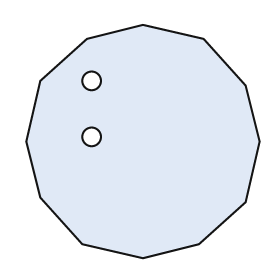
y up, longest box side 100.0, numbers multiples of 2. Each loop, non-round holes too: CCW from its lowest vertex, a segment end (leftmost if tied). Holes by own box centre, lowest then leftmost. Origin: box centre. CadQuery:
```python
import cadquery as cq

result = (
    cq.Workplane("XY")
    .moveTo(0.0, -50.0)
    .lineTo(24.0, -44.0)
    .lineTo(44.0, -26.0)
    .lineTo(50.0, 0.0)
    .lineTo(44.0, 24.0)
    .lineTo(26.0, 44.0)
    .lineTo(0.0, 50.0)
    .lineTo(-24.0, 44.0)
    .lineTo(-44.0, 26.0)
    .lineTo(-50.0, 0.0)
    .lineTo(-44.0, -24.0)
    .lineTo(-26.0, -44.0)
    .close()
    .moveTo(-22.0, 2.0)
    .circle(4.0)
    .moveTo(-22.0, 26.0)
    .circle(4.0)
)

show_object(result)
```